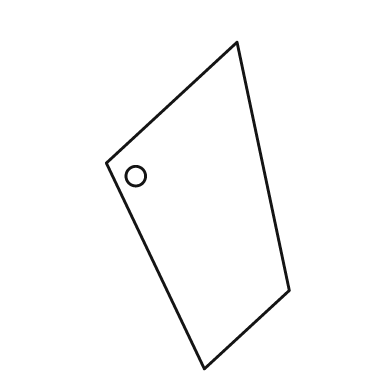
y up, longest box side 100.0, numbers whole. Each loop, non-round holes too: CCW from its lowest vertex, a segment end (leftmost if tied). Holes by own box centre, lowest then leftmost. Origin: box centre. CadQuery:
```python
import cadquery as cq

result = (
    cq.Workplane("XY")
    .moveTo(2.0, -50.0)
    .lineTo(28.0, -26.0)
    .lineTo(12.0, 50.0)
    .lineTo(-28.0, 13.0)
    .close()
    .moveTo(-19.0, 9.0)
    .circle(3.0)
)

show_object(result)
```